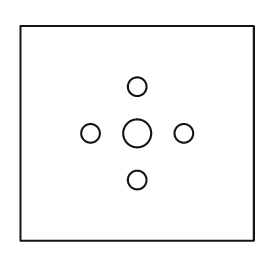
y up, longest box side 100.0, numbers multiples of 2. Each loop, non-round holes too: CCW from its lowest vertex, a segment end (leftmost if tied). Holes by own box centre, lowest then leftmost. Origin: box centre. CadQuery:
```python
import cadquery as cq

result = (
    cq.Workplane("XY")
    .moveTo(-50.0, -46.0)
    .lineTo(50.0, -46.0)
    .lineTo(50.0, 46.0)
    .lineTo(-50.0, 46.0)
    .close()
    .moveTo(0.0, -20.0)
    .circle(4.0)
    .moveTo(-20.0, 0.0)
    .circle(4.0)
    .moveTo(0.0, 0.0)
    .circle(6.0)
    .moveTo(20.0, 0.0)
    .circle(4.0)
    .moveTo(0.0, 20.0)
    .circle(4.0)
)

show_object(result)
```